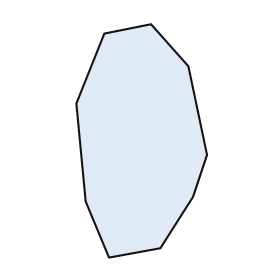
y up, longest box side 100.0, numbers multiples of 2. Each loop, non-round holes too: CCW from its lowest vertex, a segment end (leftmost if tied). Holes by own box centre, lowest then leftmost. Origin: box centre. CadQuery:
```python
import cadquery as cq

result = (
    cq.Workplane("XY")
    .moveTo(-14.0, -50.0)
    .lineTo(8.0, -46.0)
    .lineTo(22.0, -24.0)
    .lineTo(28.0, -6.0)
    .lineTo(20.0, 32.0)
    .lineTo(4.0, 50.0)
    .lineTo(-16.0, 46.0)
    .lineTo(-28.0, 16.0)
    .lineTo(-24.0, -26.0)
    .close()
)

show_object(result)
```